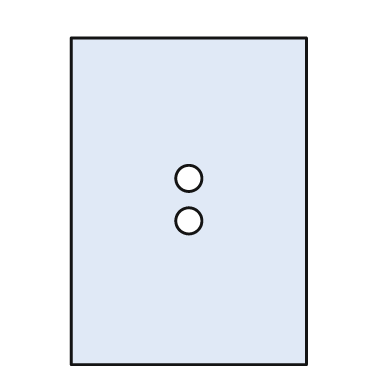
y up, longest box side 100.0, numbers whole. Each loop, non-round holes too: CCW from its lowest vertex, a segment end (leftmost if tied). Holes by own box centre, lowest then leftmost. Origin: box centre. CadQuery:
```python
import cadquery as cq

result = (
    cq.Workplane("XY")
    .moveTo(-36.0, -50.0)
    .lineTo(36.0, -50.0)
    .lineTo(36.0, 50.0)
    .lineTo(-36.0, 50.0)
    .close()
    .moveTo(0.0, -6.0)
    .circle(4.0)
    .moveTo(0.0, 7.0)
    .circle(4.0)
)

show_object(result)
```